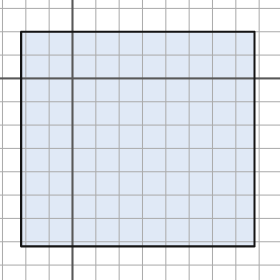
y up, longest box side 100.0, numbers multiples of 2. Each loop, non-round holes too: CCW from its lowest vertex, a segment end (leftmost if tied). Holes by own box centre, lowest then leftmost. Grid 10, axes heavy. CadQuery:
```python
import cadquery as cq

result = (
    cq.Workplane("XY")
    .moveTo(-22.0, -72.0)
    .lineTo(78.0, -72.0)
    .lineTo(78.0, 20.0)
    .lineTo(-22.0, 20.0)
    .close()
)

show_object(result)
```